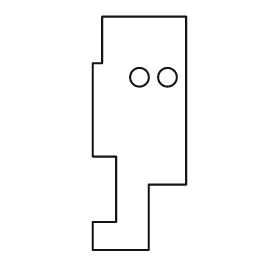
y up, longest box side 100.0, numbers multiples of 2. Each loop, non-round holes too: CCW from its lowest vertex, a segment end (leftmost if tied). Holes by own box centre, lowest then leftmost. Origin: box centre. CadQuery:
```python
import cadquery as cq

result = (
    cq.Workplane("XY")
    .moveTo(-20.0, -50.0)
    .lineTo(4.0, -50.0)
    .lineTo(4.0, -22.0)
    .lineTo(20.0, -22.0)
    .lineTo(20.0, 50.0)
    .lineTo(-16.0, 50.0)
    .lineTo(-16.0, 30.0)
    .lineTo(-20.0, 30.0)
    .lineTo(-20.0, -10.0)
    .lineTo(-10.0, -10.0)
    .lineTo(-10.0, -38.0)
    .lineTo(-20.0, -38.0)
    .close()
    .moveTo(0.0, 24.0)
    .circle(4.0)
    .moveTo(12.0, 24.0)
    .circle(4.0)
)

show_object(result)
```